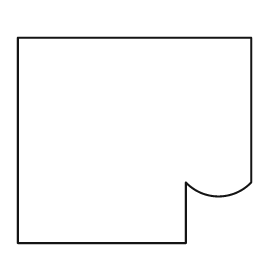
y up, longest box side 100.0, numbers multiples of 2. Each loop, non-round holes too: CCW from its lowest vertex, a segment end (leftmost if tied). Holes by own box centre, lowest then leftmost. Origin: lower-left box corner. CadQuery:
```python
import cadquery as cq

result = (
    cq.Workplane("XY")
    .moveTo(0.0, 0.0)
    .lineTo(72.0, 0.0)
    .lineTo(72.0, 26.0)
    .threePointArc((86.0, 20.0), (100.0, 26.0))
    .lineTo(100.0, 88.0)
    .lineTo(0.0, 88.0)
    .close()
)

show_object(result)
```